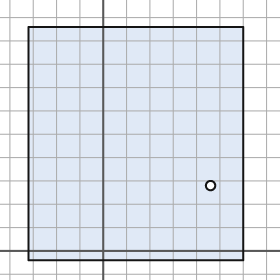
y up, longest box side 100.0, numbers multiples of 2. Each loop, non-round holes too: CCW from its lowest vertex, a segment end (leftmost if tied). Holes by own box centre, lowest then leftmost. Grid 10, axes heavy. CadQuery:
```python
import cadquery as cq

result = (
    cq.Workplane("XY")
    .moveTo(-32.0, -4.0)
    .lineTo(60.0, -4.0)
    .lineTo(60.0, 96.0)
    .lineTo(-32.0, 96.0)
    .close()
    .moveTo(46.0, 28.0)
    .circle(2.0)
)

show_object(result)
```